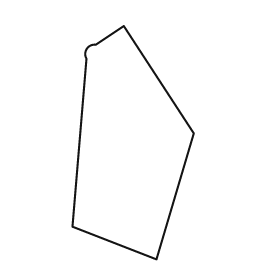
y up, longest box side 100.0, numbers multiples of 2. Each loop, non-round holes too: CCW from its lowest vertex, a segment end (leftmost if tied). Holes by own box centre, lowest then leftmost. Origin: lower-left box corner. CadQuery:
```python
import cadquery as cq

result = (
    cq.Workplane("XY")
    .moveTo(36.0, 0.0)
    .lineTo(52.0, 54.0)
    .lineTo(22.0, 100.0)
    .lineTo(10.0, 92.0)
    .threePointArc((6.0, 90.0), (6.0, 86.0))
    .lineTo(0.0, 14.0)
    .close()
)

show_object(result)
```